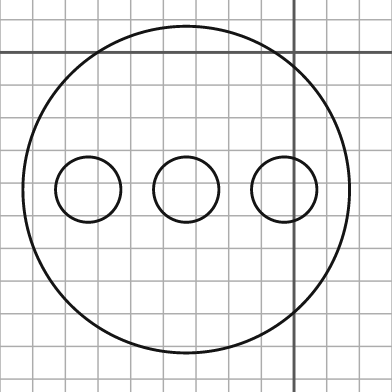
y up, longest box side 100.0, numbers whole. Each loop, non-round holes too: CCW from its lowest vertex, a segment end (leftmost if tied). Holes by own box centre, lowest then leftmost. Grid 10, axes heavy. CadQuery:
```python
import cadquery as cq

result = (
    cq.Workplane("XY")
    .moveTo(-33.0, -42.0)
    .circle(50.0)
    .moveTo(-63.0, -42.0)
    .circle(10.0)
    .moveTo(-33.0, -42.0)
    .circle(10.0)
    .moveTo(-3.0, -42.0)
    .circle(10.0)
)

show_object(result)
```